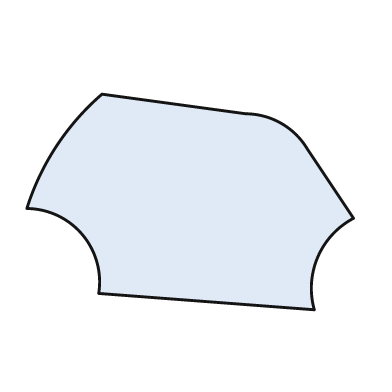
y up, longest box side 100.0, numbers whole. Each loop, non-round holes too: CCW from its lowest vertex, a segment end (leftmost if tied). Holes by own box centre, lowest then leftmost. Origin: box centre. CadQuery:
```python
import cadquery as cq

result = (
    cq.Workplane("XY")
    .moveTo(38.0, -33.0)
    .threePointArc((39.0, -17.0), (50.0, -5.0))
    .lineTo(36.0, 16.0)
    .threePointArc((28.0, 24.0), (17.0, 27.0))
    .lineTo(-27.0, 33.0)
    .threePointArc((-41.0, 17.0), (-50.0, -2.0))
    .threePointArc((-33.0, -10.0), (-28.0, -28.0))
    .close()
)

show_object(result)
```